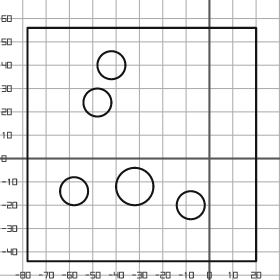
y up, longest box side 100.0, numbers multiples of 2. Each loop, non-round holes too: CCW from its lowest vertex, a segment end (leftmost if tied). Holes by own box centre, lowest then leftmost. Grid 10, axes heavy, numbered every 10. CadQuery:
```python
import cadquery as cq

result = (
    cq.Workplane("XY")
    .moveTo(-78.0, -44.0)
    .lineTo(20.0, -44.0)
    .lineTo(20.0, 56.0)
    .lineTo(-78.0, 56.0)
    .close()
    .moveTo(-8.0, -20.0)
    .circle(6.0)
    .moveTo(-58.0, -14.0)
    .circle(6.0)
    .moveTo(-32.0, -12.0)
    .circle(8.0)
    .moveTo(-48.0, 24.0)
    .circle(6.0)
    .moveTo(-42.0, 40.0)
    .circle(6.0)
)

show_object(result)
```